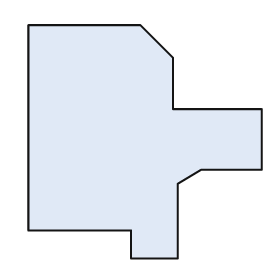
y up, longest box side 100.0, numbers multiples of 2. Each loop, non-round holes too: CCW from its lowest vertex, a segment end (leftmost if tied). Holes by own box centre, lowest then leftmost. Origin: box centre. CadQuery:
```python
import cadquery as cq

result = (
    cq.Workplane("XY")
    .moveTo(-6.0, -50.0)
    .lineTo(14.0, -50.0)
    .lineTo(14.0, -18.0)
    .lineTo(24.0, -12.0)
    .lineTo(50.0, -12.0)
    .lineTo(50.0, 14.0)
    .lineTo(12.0, 14.0)
    .lineTo(12.0, 36.0)
    .lineTo(-2.0, 50.0)
    .lineTo(-50.0, 50.0)
    .lineTo(-50.0, -38.0)
    .lineTo(-6.0, -38.0)
    .close()
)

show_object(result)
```